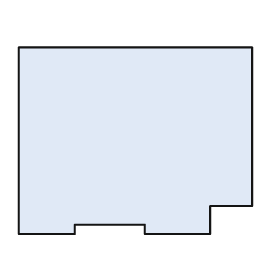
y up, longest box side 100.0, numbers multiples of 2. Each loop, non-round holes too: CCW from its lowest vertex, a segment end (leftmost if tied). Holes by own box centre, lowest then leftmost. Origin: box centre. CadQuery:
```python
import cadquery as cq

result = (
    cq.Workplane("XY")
    .moveTo(-50.0, -40.0)
    .lineTo(-26.0, -40.0)
    .lineTo(-26.0, -36.0)
    .lineTo(4.0, -36.0)
    .lineTo(4.0, -40.0)
    .lineTo(32.0, -40.0)
    .lineTo(32.0, -28.0)
    .lineTo(50.0, -28.0)
    .lineTo(50.0, 40.0)
    .lineTo(-50.0, 40.0)
    .close()
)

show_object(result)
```